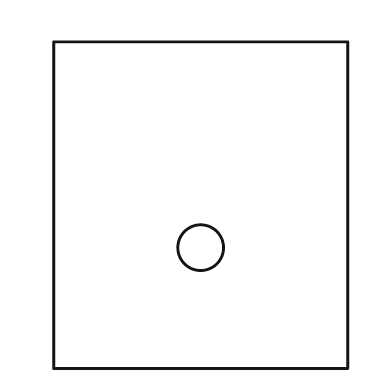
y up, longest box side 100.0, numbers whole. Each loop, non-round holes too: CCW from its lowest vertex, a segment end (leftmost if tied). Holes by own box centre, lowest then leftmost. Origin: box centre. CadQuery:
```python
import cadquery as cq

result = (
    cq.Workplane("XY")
    .moveTo(-45.0, -50.0)
    .lineTo(45.0, -50.0)
    .lineTo(45.0, 50.0)
    .lineTo(-45.0, 50.0)
    .close()
    .moveTo(0.0, -13.0)
    .circle(7.0)
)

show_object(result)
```